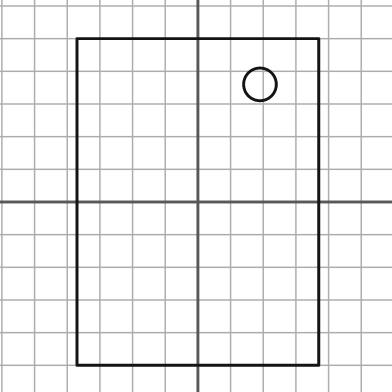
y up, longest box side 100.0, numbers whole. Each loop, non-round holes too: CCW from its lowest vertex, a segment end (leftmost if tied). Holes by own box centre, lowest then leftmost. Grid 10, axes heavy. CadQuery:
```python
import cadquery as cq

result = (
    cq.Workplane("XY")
    .moveTo(-37.0, -50.0)
    .lineTo(37.0, -50.0)
    .lineTo(37.0, 50.0)
    .lineTo(-37.0, 50.0)
    .close()
    .moveTo(19.0, 36.0)
    .circle(5.0)
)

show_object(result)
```